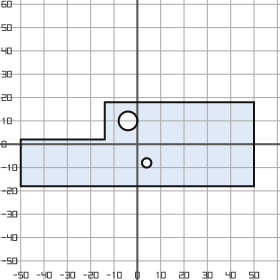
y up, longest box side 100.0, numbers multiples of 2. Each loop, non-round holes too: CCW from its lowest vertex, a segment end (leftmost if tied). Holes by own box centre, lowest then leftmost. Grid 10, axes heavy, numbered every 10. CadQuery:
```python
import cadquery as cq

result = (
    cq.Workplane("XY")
    .moveTo(-50.0, -18.0)
    .lineTo(50.0, -18.0)
    .lineTo(50.0, 18.0)
    .lineTo(-14.0, 18.0)
    .lineTo(-14.0, 2.0)
    .lineTo(-50.0, 2.0)
    .close()
    .moveTo(4.0, -8.0)
    .circle(2.0)
    .moveTo(-4.0, 10.0)
    .circle(4.0)
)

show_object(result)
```